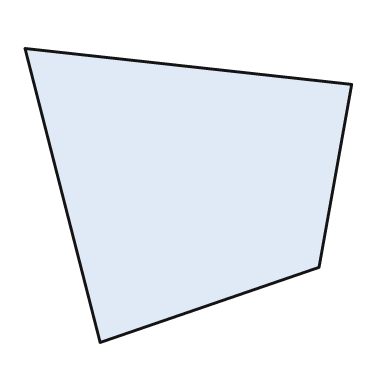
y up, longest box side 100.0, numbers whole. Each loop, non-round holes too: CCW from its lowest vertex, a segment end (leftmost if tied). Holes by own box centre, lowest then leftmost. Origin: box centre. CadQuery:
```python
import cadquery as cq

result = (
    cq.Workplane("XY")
    .moveTo(-27.0, -45.0)
    .lineTo(40.0, -22.0)
    .lineTo(50.0, 34.0)
    .lineTo(-50.0, 45.0)
    .close()
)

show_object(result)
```